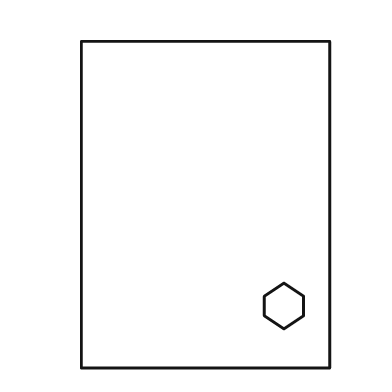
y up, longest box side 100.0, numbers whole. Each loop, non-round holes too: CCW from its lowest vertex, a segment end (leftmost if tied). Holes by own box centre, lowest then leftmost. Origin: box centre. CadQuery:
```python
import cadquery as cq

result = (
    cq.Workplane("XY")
    .moveTo(-38.0, -50.0)
    .lineTo(38.0, -50.0)
    .lineTo(38.0, 50.0)
    .lineTo(-38.0, 50.0)
    .close()
    .moveTo(24.0, -38.0)
    .lineTo(30.0, -34.0)
    .lineTo(30.0, -28.0)
    .lineTo(24.0, -24.0)
    .lineTo(18.0, -28.0)
    .lineTo(18.0, -34.0)
    .close()
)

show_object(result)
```